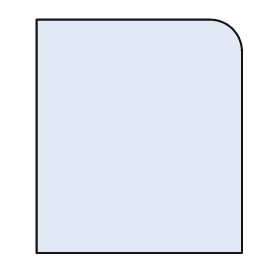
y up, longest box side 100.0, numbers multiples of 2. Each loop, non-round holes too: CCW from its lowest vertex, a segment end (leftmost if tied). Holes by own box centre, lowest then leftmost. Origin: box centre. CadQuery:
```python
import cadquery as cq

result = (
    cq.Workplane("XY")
    .moveTo(-44.0, -50.0)
    .lineTo(44.0, -50.0)
    .lineTo(44.0, 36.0)
    .threePointArc((40.0, 46.0), (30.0, 50.0))
    .lineTo(-44.0, 50.0)
    .close()
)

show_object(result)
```